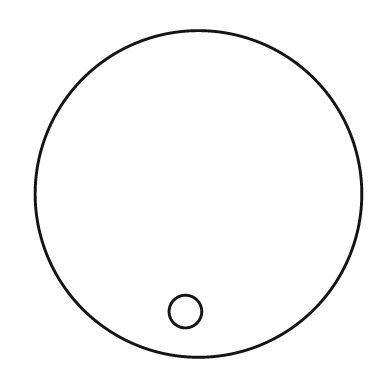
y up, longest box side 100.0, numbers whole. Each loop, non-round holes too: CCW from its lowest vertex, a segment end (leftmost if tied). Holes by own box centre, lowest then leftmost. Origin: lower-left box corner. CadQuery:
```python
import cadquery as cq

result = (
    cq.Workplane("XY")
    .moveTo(50.0, 50.0)
    .circle(50.0)
    .moveTo(46.0, 14.0)
    .circle(5.0)
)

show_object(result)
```